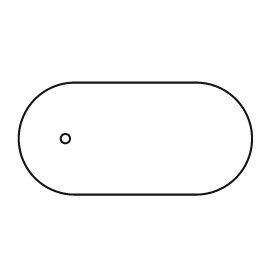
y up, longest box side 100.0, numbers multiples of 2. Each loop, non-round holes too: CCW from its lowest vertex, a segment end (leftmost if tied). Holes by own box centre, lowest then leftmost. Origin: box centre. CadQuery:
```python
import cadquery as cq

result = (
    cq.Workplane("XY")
    .moveTo(-26.0, -24.0)
    .lineTo(26.0, -24.0)
    .threePointArc((50.0, 0.0), (26.0, 24.0))
    .lineTo(-26.0, 24.0)
    .threePointArc((-50.0, 0.0), (-26.0, -24.0))
    .close()
    .moveTo(-30.0, 0.0)
    .circle(2.0)
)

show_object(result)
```